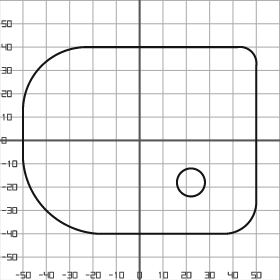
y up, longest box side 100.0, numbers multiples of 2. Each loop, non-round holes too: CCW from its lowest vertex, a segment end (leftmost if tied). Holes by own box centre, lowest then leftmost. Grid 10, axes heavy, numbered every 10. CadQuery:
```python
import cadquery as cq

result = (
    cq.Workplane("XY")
    .moveTo(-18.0, -40.0)
    .lineTo(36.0, -40.0)
    .threePointArc((46.0, -36.0), (50.0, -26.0))
    .lineTo(50.0, 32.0)
    .threePointArc((48.0, 38.0), (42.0, 40.0))
    .lineTo(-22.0, 40.0)
    .threePointArc((-42.0, 32.0), (-50.0, 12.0))
    .lineTo(-50.0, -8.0)
    .threePointArc((-40.0, -30.0), (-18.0, -40.0))
    .close()
    .moveTo(22.0, -18.0)
    .circle(6.0)
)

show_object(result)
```